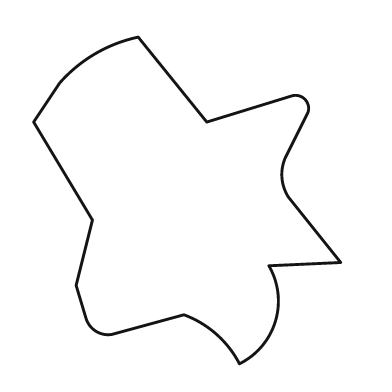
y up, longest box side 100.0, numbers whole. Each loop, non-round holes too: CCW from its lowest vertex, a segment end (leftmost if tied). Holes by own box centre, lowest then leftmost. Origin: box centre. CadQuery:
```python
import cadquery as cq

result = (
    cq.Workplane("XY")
    .moveTo(16.0, -50.0)
    .threePointArc((27.0, -37.0), (25.0, -20.0))
    .lineTo(47.0, -19.0)
    .lineTo(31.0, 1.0)
    .threePointArc((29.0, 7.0), (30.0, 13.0))
    .lineTo(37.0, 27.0)
    .threePointArc((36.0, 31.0), (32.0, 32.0))
    .lineTo(6.0, 24.0)
    .lineTo(-15.0, 50.0)
    .threePointArc((-28.0, 45.0), (-39.0, 36.0))
    .lineTo(-47.0, 24.0)
    .lineTo(-29.0, -6.0)
    .lineTo(-34.0, -26.0)
    .lineTo(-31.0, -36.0)
    .threePointArc((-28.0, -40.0), (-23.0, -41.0))
    .lineTo(-1.0, -35.0)
    .threePointArc((9.0, -41.0), (16.0, -50.0))
    .close()
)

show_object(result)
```